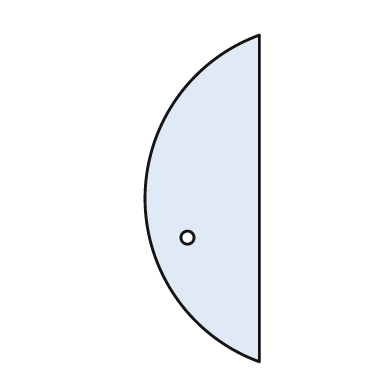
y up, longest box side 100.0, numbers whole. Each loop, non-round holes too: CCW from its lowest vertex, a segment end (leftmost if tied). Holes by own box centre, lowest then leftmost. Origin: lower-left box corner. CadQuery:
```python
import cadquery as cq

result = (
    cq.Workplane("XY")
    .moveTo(35.0, 0.0)
    .lineTo(35.0, 100.0)
    .threePointArc((0.0, 50.0), (35.0, 0.0))
    .close()
    .moveTo(13.0, 38.0)
    .circle(2.0)
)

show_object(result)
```